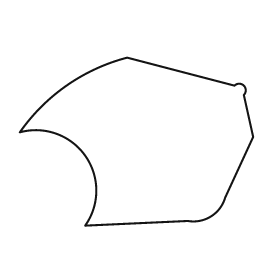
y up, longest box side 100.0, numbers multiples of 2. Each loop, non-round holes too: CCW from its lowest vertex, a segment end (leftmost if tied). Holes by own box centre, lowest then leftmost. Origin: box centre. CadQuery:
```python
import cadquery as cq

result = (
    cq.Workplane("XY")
    .moveTo(-22.0, -36.0)
    .lineTo(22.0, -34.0)
    .threePointArc((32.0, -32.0), (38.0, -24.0))
    .lineTo(50.0, 2.0)
    .lineTo(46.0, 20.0)
    .threePointArc((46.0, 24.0), (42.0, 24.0))
    .lineTo(-4.0, 36.0)
    .threePointArc((-30.0, 24.0), (-50.0, 4.0))
    .threePointArc((-22.0, -6.0), (-22.0, -36.0))
    .close()
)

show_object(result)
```